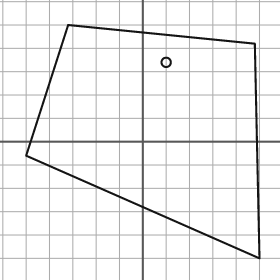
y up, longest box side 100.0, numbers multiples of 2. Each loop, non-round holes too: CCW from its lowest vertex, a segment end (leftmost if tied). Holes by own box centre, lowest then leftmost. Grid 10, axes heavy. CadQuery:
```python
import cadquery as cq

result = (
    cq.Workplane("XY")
    .moveTo(50.0, -50.0)
    .lineTo(48.0, 42.0)
    .lineTo(-32.0, 50.0)
    .lineTo(-50.0, -6.0)
    .close()
    .moveTo(10.0, 34.0)
    .circle(2.0)
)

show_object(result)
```